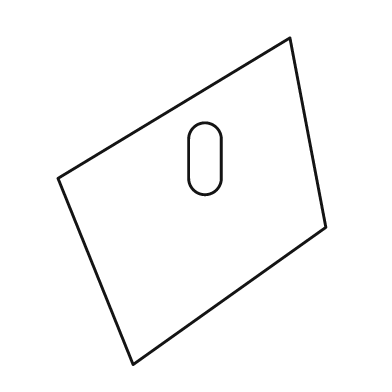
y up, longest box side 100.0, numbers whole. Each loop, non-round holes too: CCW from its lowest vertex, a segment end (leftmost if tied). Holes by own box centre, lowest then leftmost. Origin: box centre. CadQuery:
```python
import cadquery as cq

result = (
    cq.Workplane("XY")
    .moveTo(-18.0, -50.0)
    .lineTo(41.0, -8.0)
    .lineTo(30.0, 50.0)
    .lineTo(-41.0, 7.0)
    .close()
    .moveTo(-1.0, 7.0)
    .threePointArc((4.0, 2.0), (9.0, 7.0))
    .lineTo(9.0, 19.0)
    .threePointArc((4.0, 24.0), (-1.0, 19.0))
    .close()
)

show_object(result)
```